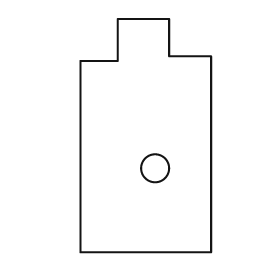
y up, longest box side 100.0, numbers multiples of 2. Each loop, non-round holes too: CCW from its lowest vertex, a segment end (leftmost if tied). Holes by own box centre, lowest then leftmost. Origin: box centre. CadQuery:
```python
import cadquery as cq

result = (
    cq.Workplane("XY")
    .moveTo(-28.0, -50.0)
    .lineTo(28.0, -50.0)
    .lineTo(28.0, 34.0)
    .lineTo(10.0, 34.0)
    .lineTo(10.0, 50.0)
    .lineTo(-12.0, 50.0)
    .lineTo(-12.0, 32.0)
    .lineTo(-28.0, 32.0)
    .close()
    .moveTo(4.0, -14.0)
    .circle(6.0)
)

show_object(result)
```